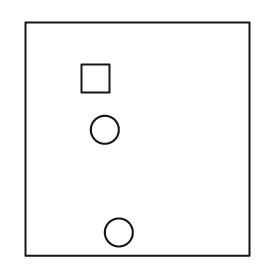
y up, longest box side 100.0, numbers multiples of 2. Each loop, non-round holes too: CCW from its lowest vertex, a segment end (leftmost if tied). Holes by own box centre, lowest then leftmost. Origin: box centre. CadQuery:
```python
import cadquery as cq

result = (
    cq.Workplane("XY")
    .moveTo(-48.0, -50.0)
    .lineTo(48.0, -50.0)
    .lineTo(48.0, 50.0)
    .lineTo(-48.0, 50.0)
    .close()
    .moveTo(-8.0, -40.0)
    .circle(6.0)
    .moveTo(-14.0, 4.0)
    .circle(6.0)
    .moveTo(-24.0, 20.0)
    .lineTo(-12.0, 20.0)
    .lineTo(-12.0, 32.0)
    .lineTo(-24.0, 32.0)
    .close()
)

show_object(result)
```